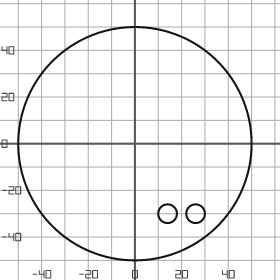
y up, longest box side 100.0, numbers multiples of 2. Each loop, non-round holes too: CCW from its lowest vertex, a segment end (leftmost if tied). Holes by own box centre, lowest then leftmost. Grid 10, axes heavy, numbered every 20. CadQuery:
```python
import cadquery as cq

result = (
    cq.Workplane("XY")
    .moveTo(0.0, 0.0)
    .circle(50.0)
    .moveTo(14.0, -30.0)
    .circle(4.0)
    .moveTo(26.0, -30.0)
    .circle(4.0)
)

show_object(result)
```